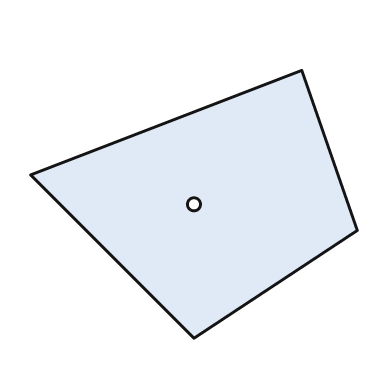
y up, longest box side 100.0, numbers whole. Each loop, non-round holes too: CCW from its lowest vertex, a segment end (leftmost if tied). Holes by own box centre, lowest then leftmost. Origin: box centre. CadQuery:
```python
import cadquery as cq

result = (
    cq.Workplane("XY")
    .moveTo(0.0, -41.0)
    .lineTo(50.0, -8.0)
    .lineTo(33.0, 41.0)
    .lineTo(-50.0, 9.0)
    .close()
    .moveTo(0.0, 0.0)
    .circle(2.0)
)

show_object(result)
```